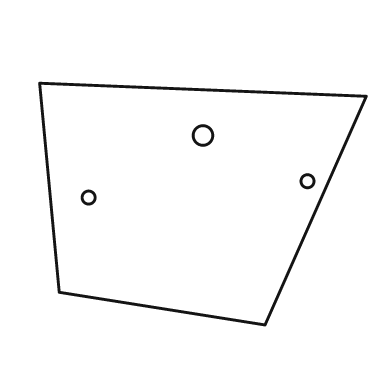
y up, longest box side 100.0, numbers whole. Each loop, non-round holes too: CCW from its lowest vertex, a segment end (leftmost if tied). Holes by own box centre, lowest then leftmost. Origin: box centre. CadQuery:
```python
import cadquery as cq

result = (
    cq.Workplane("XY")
    .moveTo(19.0, -37.0)
    .lineTo(50.0, 33.0)
    .lineTo(-50.0, 37.0)
    .lineTo(-44.0, -27.0)
    .close()
    .moveTo(-35.0, 2.0)
    .circle(2.0)
    .moveTo(32.0, 7.0)
    .circle(2.0)
    .moveTo(0.0, 21.0)
    .circle(3.0)
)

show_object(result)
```